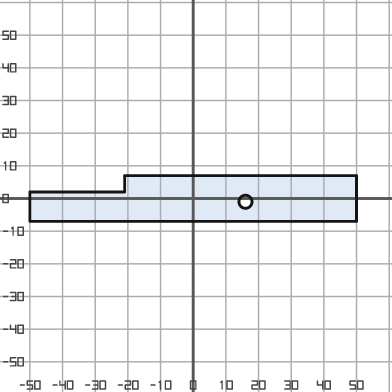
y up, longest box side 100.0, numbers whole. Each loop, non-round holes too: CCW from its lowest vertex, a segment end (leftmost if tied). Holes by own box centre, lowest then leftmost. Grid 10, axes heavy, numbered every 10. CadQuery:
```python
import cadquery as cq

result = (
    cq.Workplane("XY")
    .moveTo(-50.0, -7.0)
    .lineTo(50.0, -7.0)
    .lineTo(50.0, 7.0)
    .lineTo(-21.0, 7.0)
    .lineTo(-21.0, 2.0)
    .lineTo(-50.0, 2.0)
    .close()
    .moveTo(16.0, -1.0)
    .circle(2.0)
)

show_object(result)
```